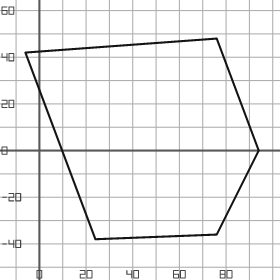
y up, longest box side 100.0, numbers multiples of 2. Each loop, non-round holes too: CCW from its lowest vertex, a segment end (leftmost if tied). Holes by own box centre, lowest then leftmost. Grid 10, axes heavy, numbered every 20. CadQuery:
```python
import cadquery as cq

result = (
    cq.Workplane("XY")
    .moveTo(24.0, -38.0)
    .lineTo(76.0, -36.0)
    .lineTo(94.0, 0.0)
    .lineTo(76.0, 48.0)
    .lineTo(-6.0, 42.0)
    .close()
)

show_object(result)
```